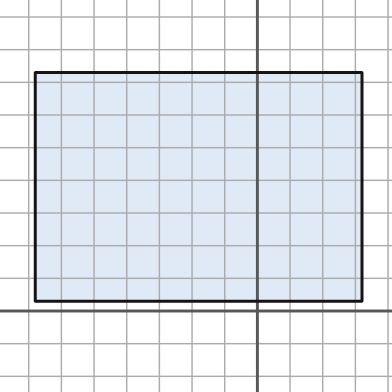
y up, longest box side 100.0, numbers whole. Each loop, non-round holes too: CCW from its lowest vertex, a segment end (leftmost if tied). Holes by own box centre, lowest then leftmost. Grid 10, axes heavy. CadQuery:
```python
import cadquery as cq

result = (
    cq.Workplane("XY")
    .moveTo(-68.0, 3.0)
    .lineTo(32.0, 3.0)
    .lineTo(32.0, 73.0)
    .lineTo(-68.0, 73.0)
    .close()
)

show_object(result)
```